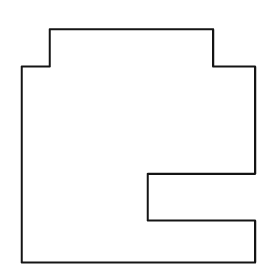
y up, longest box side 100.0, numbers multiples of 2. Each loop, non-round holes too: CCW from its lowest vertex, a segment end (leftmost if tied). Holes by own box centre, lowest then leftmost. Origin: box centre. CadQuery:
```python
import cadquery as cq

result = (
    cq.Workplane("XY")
    .moveTo(-50.0, -50.0)
    .lineTo(50.0, -50.0)
    .lineTo(50.0, -32.0)
    .lineTo(4.0, -32.0)
    .lineTo(4.0, -12.0)
    .lineTo(50.0, -12.0)
    .lineTo(50.0, 34.0)
    .lineTo(32.0, 34.0)
    .lineTo(32.0, 50.0)
    .lineTo(-38.0, 50.0)
    .lineTo(-38.0, 34.0)
    .lineTo(-50.0, 34.0)
    .close()
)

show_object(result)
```